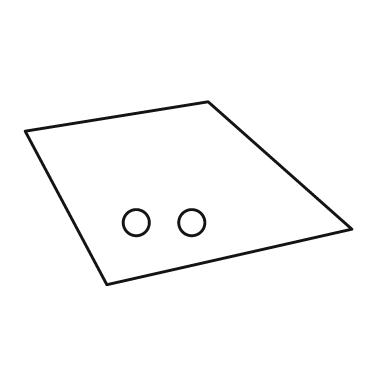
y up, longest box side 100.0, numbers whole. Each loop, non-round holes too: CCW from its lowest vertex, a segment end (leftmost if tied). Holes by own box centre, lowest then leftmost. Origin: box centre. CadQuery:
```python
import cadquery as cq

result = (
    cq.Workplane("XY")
    .moveTo(-25.0, -28.0)
    .lineTo(50.0, -11.0)
    .lineTo(6.0, 28.0)
    .lineTo(-50.0, 19.0)
    .close()
    .moveTo(-16.0, -9.0)
    .circle(4.0)
    .moveTo(1.0, -9.0)
    .circle(4.0)
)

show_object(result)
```